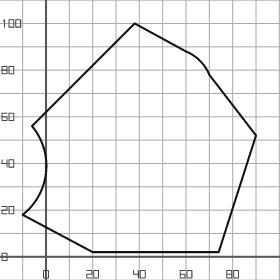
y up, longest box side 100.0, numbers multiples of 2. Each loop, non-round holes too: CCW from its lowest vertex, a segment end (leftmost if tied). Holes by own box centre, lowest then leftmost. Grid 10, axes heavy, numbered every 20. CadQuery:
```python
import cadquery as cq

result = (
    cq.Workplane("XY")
    .moveTo(20.0, 2.0)
    .lineTo(74.0, 2.0)
    .lineTo(90.0, 52.0)
    .lineTo(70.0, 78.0)
    .threePointArc((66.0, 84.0), (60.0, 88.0))
    .lineTo(38.0, 100.0)
    .lineTo(-6.0, 56.0)
    .threePointArc((0.0, 36.0), (-10.0, 18.0))
    .close()
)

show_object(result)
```